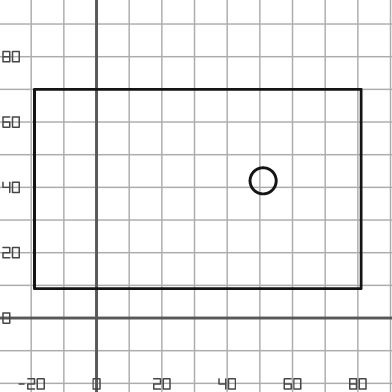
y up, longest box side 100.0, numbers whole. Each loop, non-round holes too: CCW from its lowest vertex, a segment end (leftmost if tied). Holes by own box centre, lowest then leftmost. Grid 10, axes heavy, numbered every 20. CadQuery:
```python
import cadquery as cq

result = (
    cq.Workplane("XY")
    .moveTo(-19.0, 9.0)
    .lineTo(81.0, 9.0)
    .lineTo(81.0, 70.0)
    .lineTo(-19.0, 70.0)
    .close()
    .moveTo(51.0, 42.0)
    .circle(4.0)
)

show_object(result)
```